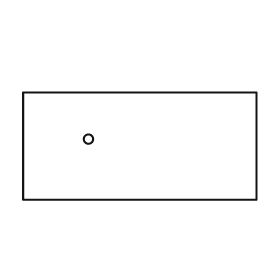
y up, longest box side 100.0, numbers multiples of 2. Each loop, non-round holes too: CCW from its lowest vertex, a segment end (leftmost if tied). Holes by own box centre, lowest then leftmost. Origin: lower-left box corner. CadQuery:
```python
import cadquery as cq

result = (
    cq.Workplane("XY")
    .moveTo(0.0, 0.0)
    .lineTo(100.0, 0.0)
    .lineTo(100.0, 46.0)
    .lineTo(0.0, 46.0)
    .close()
    .moveTo(28.0, 26.0)
    .circle(2.0)
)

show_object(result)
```